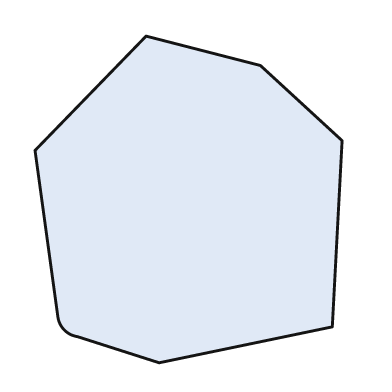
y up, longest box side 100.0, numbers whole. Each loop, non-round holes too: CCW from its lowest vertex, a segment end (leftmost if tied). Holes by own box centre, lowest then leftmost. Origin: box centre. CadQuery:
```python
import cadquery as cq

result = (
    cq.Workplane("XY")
    .moveTo(-9.0, -50.0)
    .lineTo(44.0, -39.0)
    .lineTo(47.0, 18.0)
    .lineTo(22.0, 41.0)
    .lineTo(-13.0, 50.0)
    .lineTo(-47.0, 15.0)
    .lineTo(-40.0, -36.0)
    .threePointArc((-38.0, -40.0), (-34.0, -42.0))
    .close()
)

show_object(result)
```